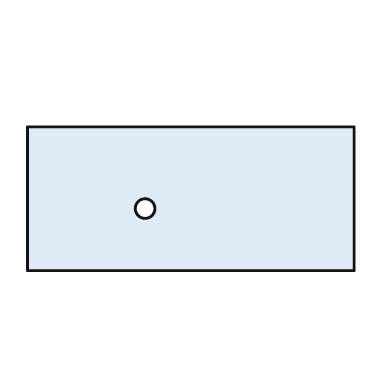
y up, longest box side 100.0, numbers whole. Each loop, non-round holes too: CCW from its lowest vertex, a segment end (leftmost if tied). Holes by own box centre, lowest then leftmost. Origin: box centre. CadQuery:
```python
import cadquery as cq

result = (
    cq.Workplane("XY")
    .moveTo(-50.0, -22.0)
    .lineTo(50.0, -22.0)
    .lineTo(50.0, 22.0)
    .lineTo(-50.0, 22.0)
    .close()
    .moveTo(-14.0, -3.0)
    .circle(3.0)
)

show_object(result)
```